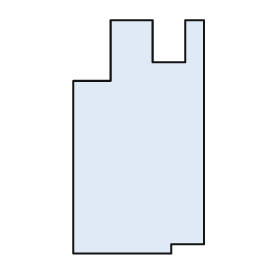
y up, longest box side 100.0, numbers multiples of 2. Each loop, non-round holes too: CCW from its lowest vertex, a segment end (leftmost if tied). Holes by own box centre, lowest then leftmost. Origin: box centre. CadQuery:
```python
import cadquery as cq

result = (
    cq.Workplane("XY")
    .moveTo(-28.0, -50.0)
    .lineTo(14.0, -50.0)
    .lineTo(14.0, -46.0)
    .lineTo(28.0, -46.0)
    .lineTo(28.0, 50.0)
    .lineTo(20.0, 50.0)
    .lineTo(20.0, 32.0)
    .lineTo(6.0, 32.0)
    .lineTo(6.0, 50.0)
    .lineTo(-12.0, 50.0)
    .lineTo(-12.0, 24.0)
    .lineTo(-28.0, 24.0)
    .close()
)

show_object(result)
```